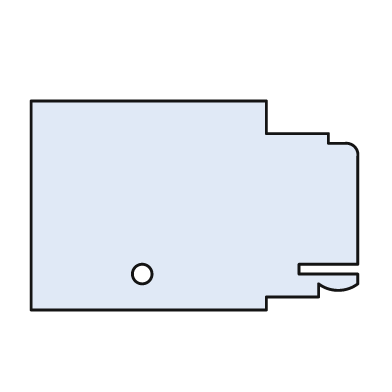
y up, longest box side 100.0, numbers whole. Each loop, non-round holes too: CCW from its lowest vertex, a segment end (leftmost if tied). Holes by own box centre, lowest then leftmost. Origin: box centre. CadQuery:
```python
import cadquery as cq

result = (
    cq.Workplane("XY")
    .moveTo(-50.0, -32.0)
    .lineTo(22.0, -32.0)
    .lineTo(22.0, -28.0)
    .lineTo(38.0, -28.0)
    .lineTo(38.0, -24.0)
    .threePointArc((44.0, -26.0), (50.0, -24.0))
    .lineTo(50.0, -21.0)
    .lineTo(32.0, -21.0)
    .lineTo(32.0, -18.0)
    .lineTo(50.0, -18.0)
    .lineTo(50.0, 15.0)
    .threePointArc((49.0, 18.0), (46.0, 19.0))
    .lineTo(41.0, 19.0)
    .lineTo(41.0, 22.0)
    .lineTo(22.0, 22.0)
    .lineTo(22.0, 32.0)
    .lineTo(-50.0, 32.0)
    .close()
    .moveTo(-16.0, -21.0)
    .circle(3.0)
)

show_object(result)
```